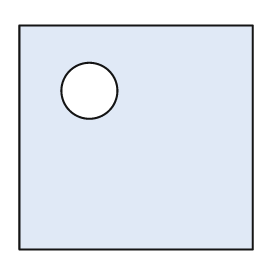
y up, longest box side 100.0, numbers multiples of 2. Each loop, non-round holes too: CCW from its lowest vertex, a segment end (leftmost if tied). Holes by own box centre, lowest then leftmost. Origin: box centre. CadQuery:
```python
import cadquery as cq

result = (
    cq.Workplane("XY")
    .moveTo(-50.0, -48.0)
    .lineTo(50.0, -48.0)
    .lineTo(50.0, 48.0)
    .lineTo(-50.0, 48.0)
    .close()
    .moveTo(-20.0, 20.0)
    .circle(12.0)
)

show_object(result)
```